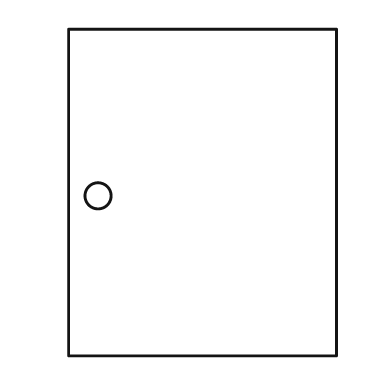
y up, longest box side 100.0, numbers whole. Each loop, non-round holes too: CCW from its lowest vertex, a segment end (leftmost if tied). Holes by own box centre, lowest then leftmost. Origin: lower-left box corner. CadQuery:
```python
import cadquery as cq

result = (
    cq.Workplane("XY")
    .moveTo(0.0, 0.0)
    .lineTo(82.0, 0.0)
    .lineTo(82.0, 100.0)
    .lineTo(0.0, 100.0)
    .close()
    .moveTo(9.0, 49.0)
    .circle(4.0)
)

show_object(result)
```